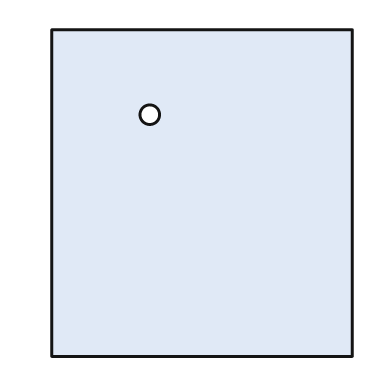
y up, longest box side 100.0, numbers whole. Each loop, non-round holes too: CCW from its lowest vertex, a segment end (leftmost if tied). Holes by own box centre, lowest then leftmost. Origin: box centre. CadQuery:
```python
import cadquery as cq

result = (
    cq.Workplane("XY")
    .moveTo(-46.0, -50.0)
    .lineTo(46.0, -50.0)
    .lineTo(46.0, 50.0)
    .lineTo(-46.0, 50.0)
    .close()
    .moveTo(-16.0, 24.0)
    .circle(3.0)
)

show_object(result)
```